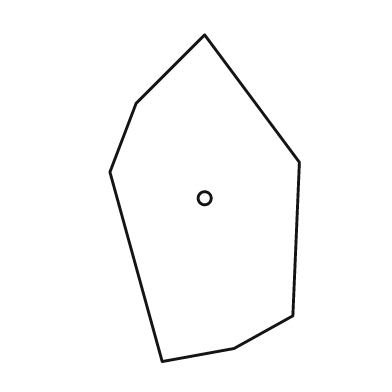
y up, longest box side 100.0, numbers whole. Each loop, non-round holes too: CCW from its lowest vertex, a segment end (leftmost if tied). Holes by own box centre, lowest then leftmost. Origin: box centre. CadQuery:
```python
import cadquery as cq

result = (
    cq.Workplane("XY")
    .moveTo(-13.0, -50.0)
    .lineTo(9.0, -46.0)
    .lineTo(27.0, -36.0)
    .lineTo(29.0, 11.0)
    .lineTo(0.0, 50.0)
    .lineTo(-21.0, 29.0)
    .lineTo(-29.0, 8.0)
    .close()
    .moveTo(0.0, 0.0)
    .circle(2.0)
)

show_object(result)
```